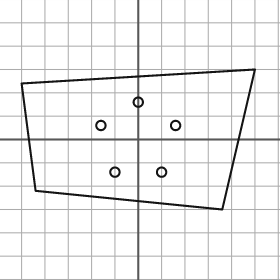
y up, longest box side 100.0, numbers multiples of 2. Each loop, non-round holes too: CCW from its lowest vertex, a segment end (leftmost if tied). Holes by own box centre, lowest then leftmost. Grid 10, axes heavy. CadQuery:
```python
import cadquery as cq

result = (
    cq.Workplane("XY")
    .moveTo(36.0, -30.0)
    .lineTo(50.0, 30.0)
    .lineTo(-50.0, 24.0)
    .lineTo(-44.0, -22.0)
    .close()
    .moveTo(-10.0, -14.0)
    .circle(2.0)
    .moveTo(10.0, -14.0)
    .circle(2.0)
    .moveTo(-16.0, 6.0)
    .circle(2.0)
    .moveTo(16.0, 6.0)
    .circle(2.0)
    .moveTo(0.0, 16.0)
    .circle(2.0)
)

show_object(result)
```